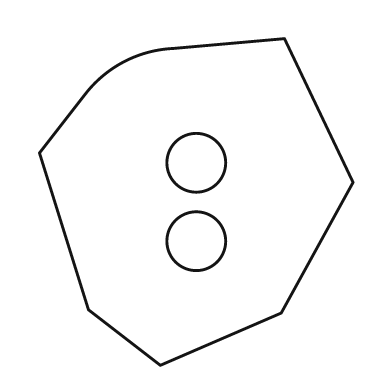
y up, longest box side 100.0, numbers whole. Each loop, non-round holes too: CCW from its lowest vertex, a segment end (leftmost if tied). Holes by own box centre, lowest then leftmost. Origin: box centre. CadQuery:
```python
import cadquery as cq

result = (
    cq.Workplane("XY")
    .moveTo(-11.0, -50.0)
    .lineTo(26.0, -34.0)
    .lineTo(48.0, 6.0)
    .lineTo(27.0, 50.0)
    .lineTo(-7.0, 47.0)
    .threePointArc((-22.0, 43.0), (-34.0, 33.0))
    .lineTo(-48.0, 15.0)
    .lineTo(-33.0, -33.0)
    .close()
    .moveTo(0.0, -12.0)
    .circle(9.0)
    .moveTo(0.0, 12.0)
    .circle(9.0)
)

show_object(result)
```